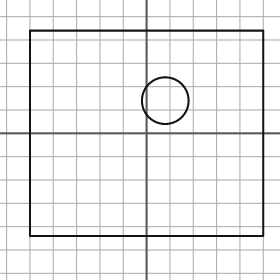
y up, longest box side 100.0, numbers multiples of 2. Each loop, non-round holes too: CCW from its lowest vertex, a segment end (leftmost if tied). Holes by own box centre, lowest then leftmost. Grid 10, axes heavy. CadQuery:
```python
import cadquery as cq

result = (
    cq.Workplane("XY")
    .moveTo(-50.0, -44.0)
    .lineTo(50.0, -44.0)
    .lineTo(50.0, 44.0)
    .lineTo(-50.0, 44.0)
    .close()
    .moveTo(8.0, 14.0)
    .circle(10.0)
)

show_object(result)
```